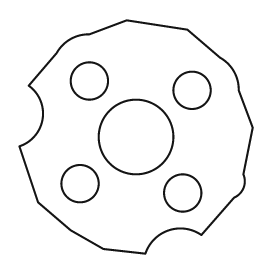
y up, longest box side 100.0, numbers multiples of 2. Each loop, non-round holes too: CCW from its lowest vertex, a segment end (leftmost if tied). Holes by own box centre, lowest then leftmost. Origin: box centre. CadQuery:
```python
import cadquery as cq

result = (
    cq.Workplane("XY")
    .moveTo(4.0, -50.0)
    .threePointArc((14.0, -40.0), (28.0, -42.0))
    .lineTo(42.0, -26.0)
    .threePointArc((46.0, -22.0), (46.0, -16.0))
    .lineTo(50.0, 4.0)
    .lineTo(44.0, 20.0)
    .threePointArc((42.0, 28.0), (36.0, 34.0))
    .lineTo(22.0, 46.0)
    .lineTo(-4.0, 50.0)
    .lineTo(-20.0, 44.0)
    .threePointArc((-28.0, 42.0), (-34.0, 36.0))
    .lineTo(-46.0, 22.0)
    .threePointArc((-40.0, 8.0), (-50.0, -4.0))
    .lineTo(-42.0, -28.0)
    .lineTo(-28.0, -40.0)
    .lineTo(-14.0, -48.0)
    .close()
    .moveTo(20.0, -24.0)
    .circle(8.0)
    .moveTo(-24.0, -20.0)
    .circle(8.0)
    .moveTo(0.0, 0.0)
    .circle(16.0)
    .moveTo(24.0, 20.0)
    .circle(8.0)
    .moveTo(-20.0, 24.0)
    .circle(8.0)
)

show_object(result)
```